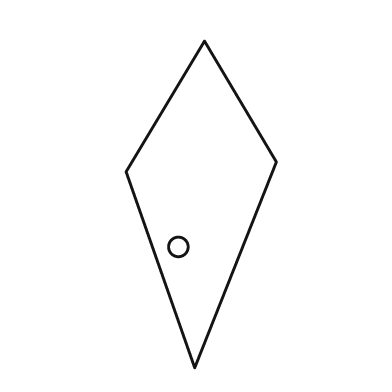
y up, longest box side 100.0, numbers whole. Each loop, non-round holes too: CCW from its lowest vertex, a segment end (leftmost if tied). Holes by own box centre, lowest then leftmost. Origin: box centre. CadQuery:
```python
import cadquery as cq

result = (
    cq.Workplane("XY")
    .moveTo(-2.0, -50.0)
    .lineTo(23.0, 13.0)
    .lineTo(1.0, 50.0)
    .lineTo(-23.0, 10.0)
    .close()
    .moveTo(-7.0, -13.0)
    .circle(3.0)
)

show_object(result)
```